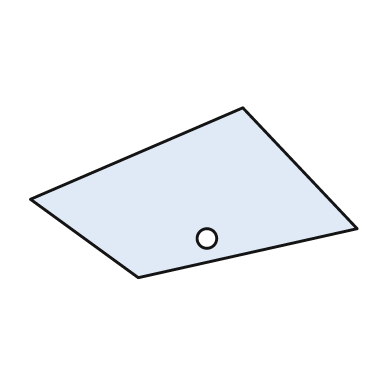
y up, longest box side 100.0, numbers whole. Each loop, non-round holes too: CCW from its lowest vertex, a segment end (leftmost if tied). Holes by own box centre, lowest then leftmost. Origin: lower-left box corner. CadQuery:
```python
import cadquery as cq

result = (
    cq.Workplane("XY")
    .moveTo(33.0, 0.0)
    .lineTo(100.0, 15.0)
    .lineTo(65.0, 52.0)
    .lineTo(0.0, 24.0)
    .close()
    .moveTo(54.0, 12.0)
    .circle(3.0)
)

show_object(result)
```